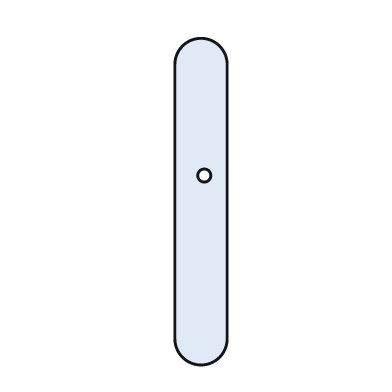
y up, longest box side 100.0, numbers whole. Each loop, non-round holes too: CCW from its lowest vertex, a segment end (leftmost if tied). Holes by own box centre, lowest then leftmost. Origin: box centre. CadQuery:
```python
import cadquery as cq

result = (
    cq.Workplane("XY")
    .moveTo(-8.0, -42.0)
    .threePointArc((0.0, -50.0), (8.0, -42.0))
    .lineTo(8.0, 42.0)
    .threePointArc((0.0, 50.0), (-8.0, 42.0))
    .close()
    .moveTo(1.0, 8.0)
    .circle(2.0)
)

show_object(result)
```